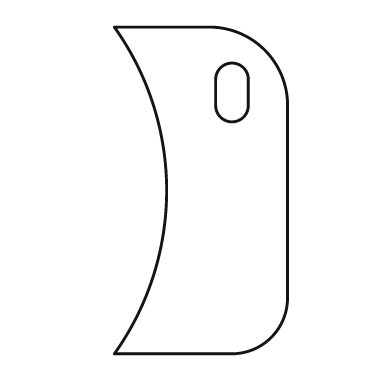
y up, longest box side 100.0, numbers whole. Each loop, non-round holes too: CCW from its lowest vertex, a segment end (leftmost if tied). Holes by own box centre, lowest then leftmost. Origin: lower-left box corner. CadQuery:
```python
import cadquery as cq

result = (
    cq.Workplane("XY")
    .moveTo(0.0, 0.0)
    .lineTo(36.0, 0.0)
    .threePointArc((48.0, 5.0), (53.0, 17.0))
    .lineTo(53.0, 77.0)
    .threePointArc((46.0, 93.0), (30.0, 100.0))
    .lineTo(0.0, 100.0)
    .threePointArc((16.0, 50.0), (0.0, 0.0))
    .close()
    .moveTo(31.0, 76.0)
    .threePointArc((36.0, 71.0), (41.0, 76.0))
    .lineTo(41.0, 84.0)
    .threePointArc((36.0, 89.0), (31.0, 84.0))
    .close()
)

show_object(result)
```